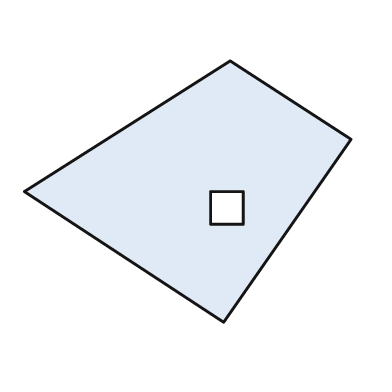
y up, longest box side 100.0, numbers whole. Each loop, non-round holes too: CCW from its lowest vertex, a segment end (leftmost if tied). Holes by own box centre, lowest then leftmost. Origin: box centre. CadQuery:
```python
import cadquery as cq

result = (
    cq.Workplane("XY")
    .moveTo(11.0, -40.0)
    .lineTo(50.0, 16.0)
    .lineTo(13.0, 40.0)
    .lineTo(-50.0, 0.0)
    .close()
    .moveTo(7.0, -10.0)
    .lineTo(17.0, -10.0)
    .lineTo(17.0, 0.0)
    .lineTo(7.0, 0.0)
    .close()
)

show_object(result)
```